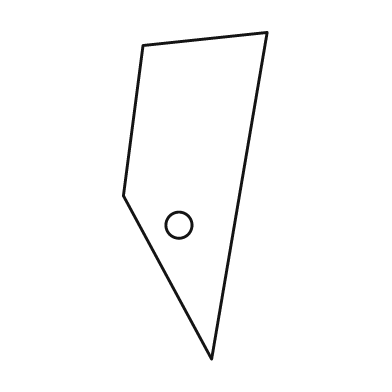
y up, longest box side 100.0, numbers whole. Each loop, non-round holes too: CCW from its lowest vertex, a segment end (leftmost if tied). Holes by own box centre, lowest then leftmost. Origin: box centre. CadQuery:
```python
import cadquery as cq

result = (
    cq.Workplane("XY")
    .moveTo(5.0, -50.0)
    .lineTo(22.0, 50.0)
    .lineTo(-16.0, 46.0)
    .lineTo(-22.0, 0.0)
    .close()
    .moveTo(-5.0, -9.0)
    .circle(4.0)
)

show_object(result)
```